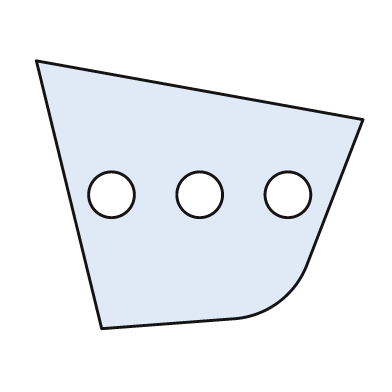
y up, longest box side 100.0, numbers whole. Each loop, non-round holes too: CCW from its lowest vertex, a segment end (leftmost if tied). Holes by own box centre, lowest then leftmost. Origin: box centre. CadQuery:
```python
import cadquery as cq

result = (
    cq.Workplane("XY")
    .moveTo(-30.0, -41.0)
    .lineTo(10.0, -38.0)
    .threePointArc((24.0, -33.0), (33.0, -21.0))
    .lineTo(50.0, 23.0)
    .lineTo(-50.0, 41.0)
    .close()
    .moveTo(-27.0, 0.0)
    .circle(7.0)
    .moveTo(0.0, 0.0)
    .circle(7.0)
    .moveTo(27.0, 0.0)
    .circle(7.0)
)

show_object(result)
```